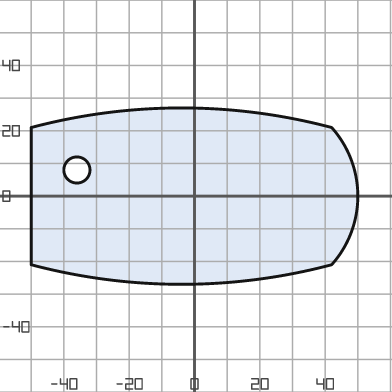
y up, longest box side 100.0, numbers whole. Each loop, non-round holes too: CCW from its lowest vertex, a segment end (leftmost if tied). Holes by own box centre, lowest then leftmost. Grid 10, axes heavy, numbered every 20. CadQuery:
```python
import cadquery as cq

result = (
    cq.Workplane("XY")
    .moveTo(-50.0, -21.0)
    .threePointArc((-4.0, -27.0), (42.0, -21.0))
    .threePointArc((50.0, 0.0), (42.0, 21.0))
    .threePointArc((-4.0, 27.0), (-50.0, 21.0))
    .close()
    .moveTo(-36.0, 8.0)
    .circle(4.0)
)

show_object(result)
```